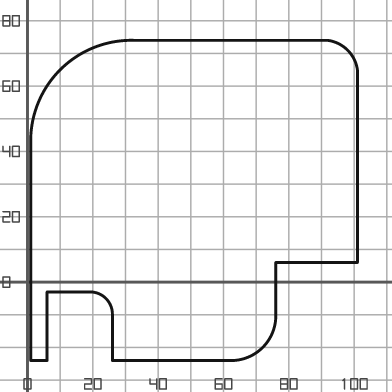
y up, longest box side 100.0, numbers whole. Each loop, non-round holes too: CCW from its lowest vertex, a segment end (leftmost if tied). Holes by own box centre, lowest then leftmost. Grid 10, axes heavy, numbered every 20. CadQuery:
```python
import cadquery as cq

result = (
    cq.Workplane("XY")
    .moveTo(1.0, -24.0)
    .lineTo(6.0, -24.0)
    .lineTo(6.0, -3.0)
    .lineTo(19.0, -3.0)
    .threePointArc((24.0, -5.0), (26.0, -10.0))
    .lineTo(26.0, -24.0)
    .lineTo(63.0, -24.0)
    .threePointArc((72.0, -20.0), (76.0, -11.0))
    .lineTo(76.0, 6.0)
    .lineTo(101.0, 6.0)
    .lineTo(101.0, 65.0)
    .threePointArc((98.0, 71.0), (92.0, 74.0))
    .lineTo(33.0, 74.0)
    .threePointArc((10.0, 65.0), (1.0, 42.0))
    .close()
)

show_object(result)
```